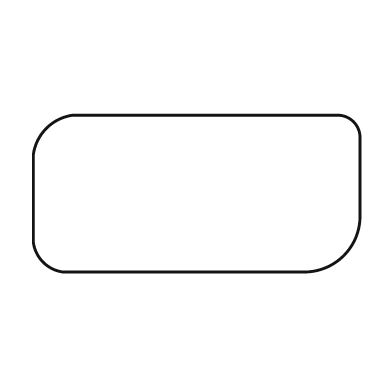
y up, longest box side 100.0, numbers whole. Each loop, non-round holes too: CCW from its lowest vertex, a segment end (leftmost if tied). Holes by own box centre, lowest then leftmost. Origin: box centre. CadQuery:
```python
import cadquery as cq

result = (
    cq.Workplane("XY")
    .moveTo(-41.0, -24.0)
    .lineTo(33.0, -24.0)
    .threePointArc((45.0, -19.0), (50.0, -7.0))
    .lineTo(50.0, 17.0)
    .threePointArc((48.0, 22.0), (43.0, 24.0))
    .lineTo(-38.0, 24.0)
    .threePointArc((-46.0, 20.0), (-50.0, 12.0))
    .lineTo(-50.0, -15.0)
    .threePointArc((-47.0, -21.0), (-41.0, -24.0))
    .close()
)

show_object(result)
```